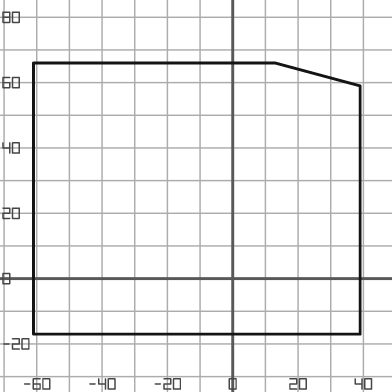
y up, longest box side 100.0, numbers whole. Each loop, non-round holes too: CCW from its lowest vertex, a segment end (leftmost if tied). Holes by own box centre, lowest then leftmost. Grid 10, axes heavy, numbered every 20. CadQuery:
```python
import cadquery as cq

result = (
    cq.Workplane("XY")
    .moveTo(-61.0, -17.0)
    .lineTo(39.0, -17.0)
    .lineTo(39.0, 59.0)
    .lineTo(13.0, 66.0)
    .lineTo(-61.0, 66.0)
    .close()
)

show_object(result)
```